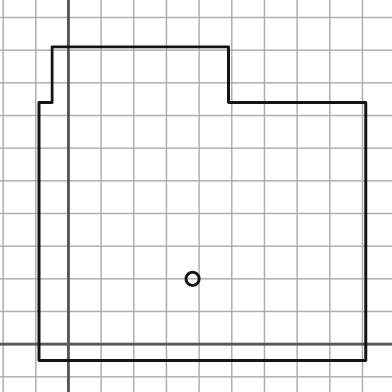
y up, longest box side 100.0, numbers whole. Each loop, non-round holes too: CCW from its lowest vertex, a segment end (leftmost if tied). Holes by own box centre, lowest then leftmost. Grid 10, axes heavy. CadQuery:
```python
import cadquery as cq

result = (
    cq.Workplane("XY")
    .moveTo(-9.0, -5.0)
    .lineTo(91.0, -5.0)
    .lineTo(91.0, 74.0)
    .lineTo(49.0, 74.0)
    .lineTo(49.0, 91.0)
    .lineTo(-5.0, 91.0)
    .lineTo(-5.0, 74.0)
    .lineTo(-9.0, 74.0)
    .close()
    .moveTo(38.0, 20.0)
    .circle(2.0)
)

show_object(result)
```